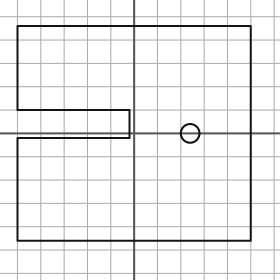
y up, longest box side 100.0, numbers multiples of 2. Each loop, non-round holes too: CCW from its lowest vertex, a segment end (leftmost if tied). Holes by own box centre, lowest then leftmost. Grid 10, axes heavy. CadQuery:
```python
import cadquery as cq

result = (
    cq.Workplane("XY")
    .moveTo(-50.0, -46.0)
    .lineTo(50.0, -46.0)
    .lineTo(50.0, 46.0)
    .lineTo(-50.0, 46.0)
    .lineTo(-50.0, 10.0)
    .lineTo(-2.0, 10.0)
    .lineTo(-2.0, -2.0)
    .lineTo(-50.0, -2.0)
    .close()
    .moveTo(24.0, 0.0)
    .circle(4.0)
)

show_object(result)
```